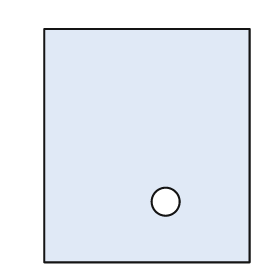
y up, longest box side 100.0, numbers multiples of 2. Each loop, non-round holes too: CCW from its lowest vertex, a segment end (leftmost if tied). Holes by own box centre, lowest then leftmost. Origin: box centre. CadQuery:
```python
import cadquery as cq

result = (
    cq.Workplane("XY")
    .moveTo(-44.0, -50.0)
    .lineTo(44.0, -50.0)
    .lineTo(44.0, 50.0)
    .lineTo(-44.0, 50.0)
    .close()
    .moveTo(8.0, -24.0)
    .circle(6.0)
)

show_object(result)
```